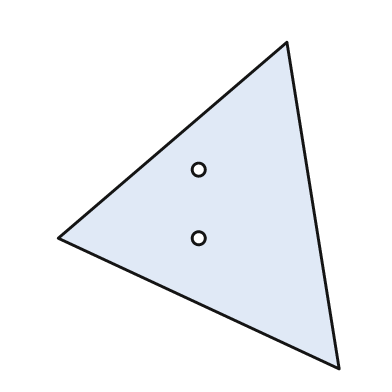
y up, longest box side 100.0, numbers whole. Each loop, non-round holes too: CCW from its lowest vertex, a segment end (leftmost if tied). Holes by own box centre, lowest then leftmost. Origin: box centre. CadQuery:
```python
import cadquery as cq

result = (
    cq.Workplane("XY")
    .moveTo(43.0, -50.0)
    .lineTo(27.0, 50.0)
    .lineTo(-43.0, -10.0)
    .close()
    .moveTo(0.0, -10.0)
    .circle(2.0)
    .moveTo(0.0, 11.0)
    .circle(2.0)
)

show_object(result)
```